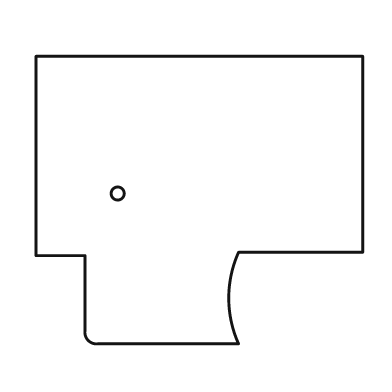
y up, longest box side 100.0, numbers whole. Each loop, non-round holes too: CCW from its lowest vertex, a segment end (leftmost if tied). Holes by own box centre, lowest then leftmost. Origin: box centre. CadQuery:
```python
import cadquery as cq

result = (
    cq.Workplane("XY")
    .moveTo(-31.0, -44.0)
    .lineTo(12.0, -44.0)
    .threePointArc((9.0, -30.0), (12.0, -16.0))
    .lineTo(50.0, -16.0)
    .lineTo(50.0, 44.0)
    .lineTo(-50.0, 44.0)
    .lineTo(-50.0, -17.0)
    .lineTo(-35.0, -17.0)
    .lineTo(-35.0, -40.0)
    .threePointArc((-34.0, -43.0), (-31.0, -44.0))
    .close()
    .moveTo(-25.0, 2.0)
    .circle(2.0)
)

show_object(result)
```